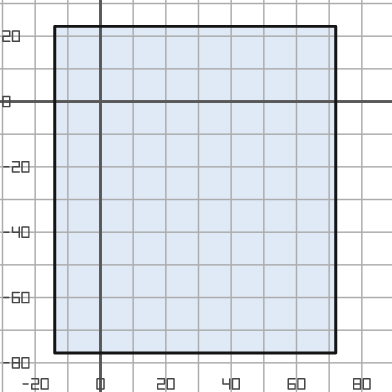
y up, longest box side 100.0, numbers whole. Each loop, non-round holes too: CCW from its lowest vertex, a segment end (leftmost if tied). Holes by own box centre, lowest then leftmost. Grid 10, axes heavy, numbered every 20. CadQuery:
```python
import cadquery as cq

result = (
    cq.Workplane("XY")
    .moveTo(-14.0, -77.0)
    .lineTo(72.0, -77.0)
    .lineTo(72.0, 23.0)
    .lineTo(-14.0, 23.0)
    .close()
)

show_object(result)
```